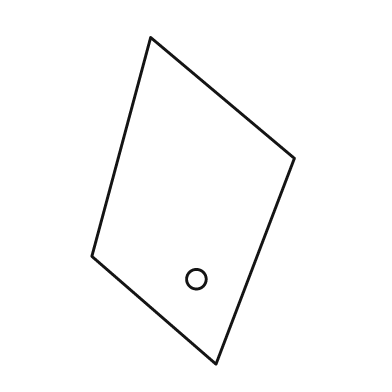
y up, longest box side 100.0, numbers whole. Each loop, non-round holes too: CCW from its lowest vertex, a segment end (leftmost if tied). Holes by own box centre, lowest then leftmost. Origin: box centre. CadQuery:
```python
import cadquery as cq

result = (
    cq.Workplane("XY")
    .moveTo(7.0, -50.0)
    .lineTo(31.0, 13.0)
    .lineTo(-13.0, 50.0)
    .lineTo(-31.0, -17.0)
    .close()
    .moveTo(1.0, -24.0)
    .circle(3.0)
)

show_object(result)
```